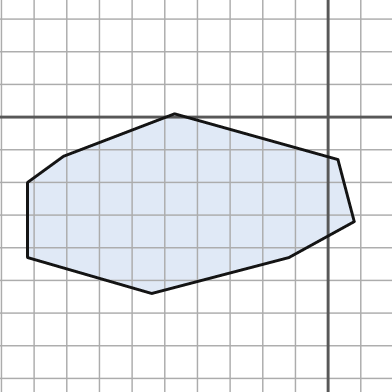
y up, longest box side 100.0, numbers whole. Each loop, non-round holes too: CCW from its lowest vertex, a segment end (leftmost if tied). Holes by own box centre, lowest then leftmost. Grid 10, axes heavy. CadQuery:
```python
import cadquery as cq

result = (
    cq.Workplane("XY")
    .moveTo(-54.0, -54.0)
    .lineTo(-12.0, -43.0)
    .lineTo(8.0, -32.0)
    .lineTo(3.0, -13.0)
    .lineTo(-47.0, 1.0)
    .lineTo(-81.0, -12.0)
    .lineTo(-92.0, -20.0)
    .lineTo(-92.0, -43.0)
    .close()
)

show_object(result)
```